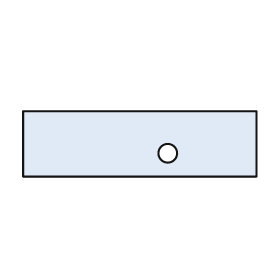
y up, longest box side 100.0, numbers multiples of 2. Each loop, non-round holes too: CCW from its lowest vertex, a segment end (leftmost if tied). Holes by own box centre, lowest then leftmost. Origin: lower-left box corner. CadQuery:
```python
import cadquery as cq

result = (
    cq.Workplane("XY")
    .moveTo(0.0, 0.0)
    .lineTo(100.0, 0.0)
    .lineTo(100.0, 28.0)
    .lineTo(0.0, 28.0)
    .close()
    .moveTo(62.0, 10.0)
    .circle(4.0)
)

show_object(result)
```